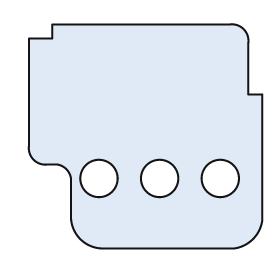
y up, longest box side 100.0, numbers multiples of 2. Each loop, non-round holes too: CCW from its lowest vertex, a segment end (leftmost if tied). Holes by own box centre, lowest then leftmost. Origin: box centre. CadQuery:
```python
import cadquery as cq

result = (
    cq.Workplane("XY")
    .moveTo(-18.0, -48.0)
    .lineTo(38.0, -48.0)
    .threePointArc((46.0, -44.0), (50.0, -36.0))
    .lineTo(50.0, 18.0)
    .lineTo(44.0, 18.0)
    .lineTo(44.0, 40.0)
    .threePointArc((42.0, 46.0), (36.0, 48.0))
    .lineTo(-40.0, 48.0)
    .lineTo(-40.0, 42.0)
    .lineTo(-50.0, 42.0)
    .lineTo(-50.0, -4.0)
    .threePointArc((-48.0, -10.0), (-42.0, -12.0))
    .lineTo(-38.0, -12.0)
    .threePointArc((-34.0, -14.0), (-32.0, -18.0))
    .lineTo(-32.0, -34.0)
    .threePointArc((-28.0, -44.0), (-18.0, -48.0))
    .close()
    .moveTo(-20.0, -18.0)
    .circle(8.0)
    .moveTo(6.0, -18.0)
    .circle(8.0)
    .moveTo(32.0, -18.0)
    .circle(8.0)
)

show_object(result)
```